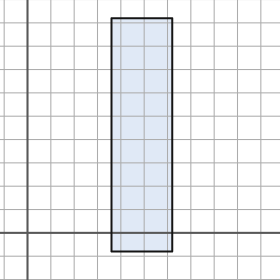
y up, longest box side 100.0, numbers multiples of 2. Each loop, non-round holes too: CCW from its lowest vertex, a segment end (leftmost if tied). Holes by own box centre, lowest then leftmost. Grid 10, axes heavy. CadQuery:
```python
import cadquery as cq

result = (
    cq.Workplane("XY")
    .moveTo(36.0, -8.0)
    .lineTo(62.0, -8.0)
    .lineTo(62.0, 92.0)
    .lineTo(36.0, 92.0)
    .close()
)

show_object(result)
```